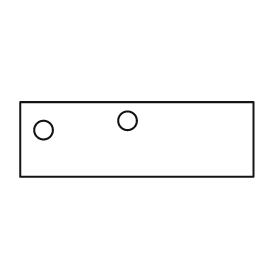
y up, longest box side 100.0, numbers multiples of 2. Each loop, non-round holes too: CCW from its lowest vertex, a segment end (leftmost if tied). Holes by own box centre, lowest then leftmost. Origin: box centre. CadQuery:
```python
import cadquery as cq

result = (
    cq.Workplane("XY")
    .moveTo(-50.0, -16.0)
    .lineTo(50.0, -16.0)
    .lineTo(50.0, 16.0)
    .lineTo(-50.0, 16.0)
    .close()
    .moveTo(-40.0, 4.0)
    .circle(4.0)
    .moveTo(-4.0, 8.0)
    .circle(4.0)
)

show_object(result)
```